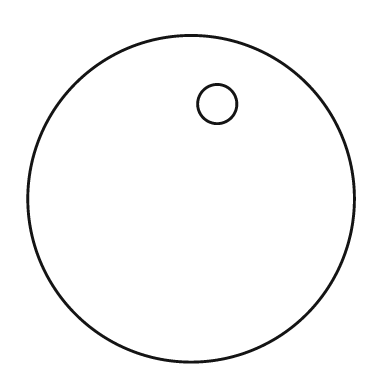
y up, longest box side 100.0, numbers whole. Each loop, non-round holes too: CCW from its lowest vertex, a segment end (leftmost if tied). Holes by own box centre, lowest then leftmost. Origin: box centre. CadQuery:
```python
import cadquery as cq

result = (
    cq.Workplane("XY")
    .moveTo(0.0, 0.0)
    .circle(50.0)
    .moveTo(8.0, 29.0)
    .circle(6.0)
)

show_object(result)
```